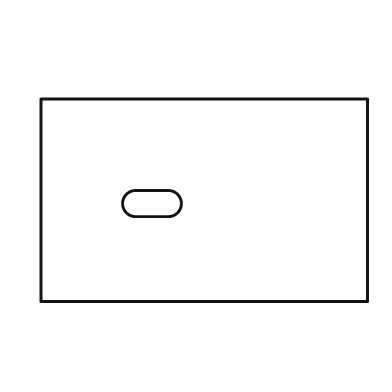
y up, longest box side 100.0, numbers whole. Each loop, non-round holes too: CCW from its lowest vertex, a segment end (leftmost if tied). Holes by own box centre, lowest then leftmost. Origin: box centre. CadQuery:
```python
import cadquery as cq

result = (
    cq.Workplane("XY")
    .moveTo(-50.0, -31.0)
    .lineTo(50.0, -31.0)
    .lineTo(50.0, 31.0)
    .lineTo(-50.0, 31.0)
    .close()
    .moveTo(-21.0, -5.0)
    .lineTo(-11.0, -5.0)
    .threePointArc((-7.0, -1.0), (-11.0, 3.0))
    .lineTo(-21.0, 3.0)
    .threePointArc((-25.0, -1.0), (-21.0, -5.0))
    .close()
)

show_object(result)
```